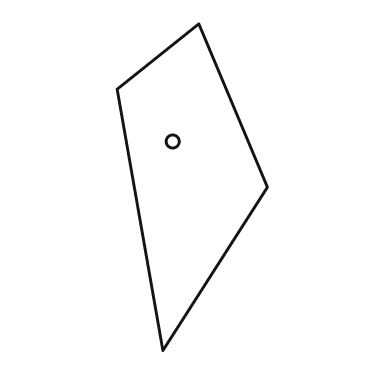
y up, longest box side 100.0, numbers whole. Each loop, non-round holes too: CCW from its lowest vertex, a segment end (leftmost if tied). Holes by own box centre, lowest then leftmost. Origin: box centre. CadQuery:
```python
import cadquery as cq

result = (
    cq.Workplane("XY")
    .moveTo(-9.0, -50.0)
    .lineTo(23.0, 0.0)
    .lineTo(2.0, 50.0)
    .lineTo(-23.0, 30.0)
    .close()
    .moveTo(-6.0, 14.0)
    .circle(2.0)
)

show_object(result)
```